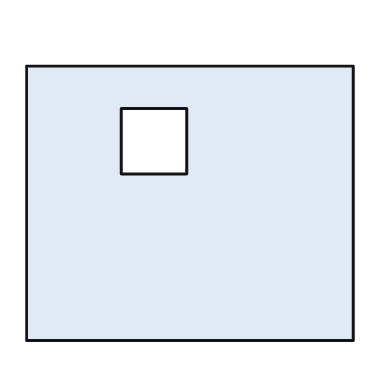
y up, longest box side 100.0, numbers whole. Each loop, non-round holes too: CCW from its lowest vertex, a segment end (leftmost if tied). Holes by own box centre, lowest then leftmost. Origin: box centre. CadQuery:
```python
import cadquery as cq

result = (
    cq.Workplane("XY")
    .moveTo(-50.0, -42.0)
    .lineTo(50.0, -42.0)
    .lineTo(50.0, 42.0)
    .lineTo(-50.0, 42.0)
    .close()
    .moveTo(-21.0, 9.0)
    .lineTo(-1.0, 9.0)
    .lineTo(-1.0, 29.0)
    .lineTo(-21.0, 29.0)
    .close()
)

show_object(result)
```